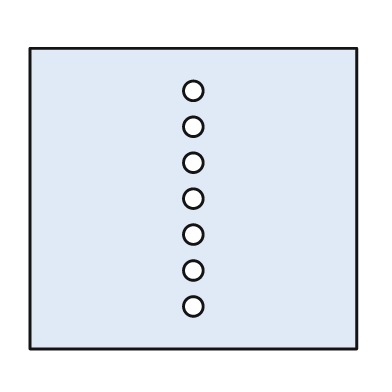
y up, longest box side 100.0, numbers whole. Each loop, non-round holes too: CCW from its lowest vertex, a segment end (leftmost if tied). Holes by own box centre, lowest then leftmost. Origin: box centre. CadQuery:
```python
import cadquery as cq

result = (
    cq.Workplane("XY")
    .moveTo(-50.0, -46.0)
    .lineTo(50.0, -46.0)
    .lineTo(50.0, 46.0)
    .lineTo(-50.0, 46.0)
    .close()
    .moveTo(0.0, -33.0)
    .circle(3.0)
    .moveTo(0.0, -22.0)
    .circle(3.0)
    .moveTo(0.0, -11.0)
    .circle(3.0)
    .moveTo(0.0, 0.0)
    .circle(3.0)
    .moveTo(0.0, 11.0)
    .circle(3.0)
    .moveTo(0.0, 22.0)
    .circle(3.0)
    .moveTo(0.0, 33.0)
    .circle(3.0)
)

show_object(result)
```